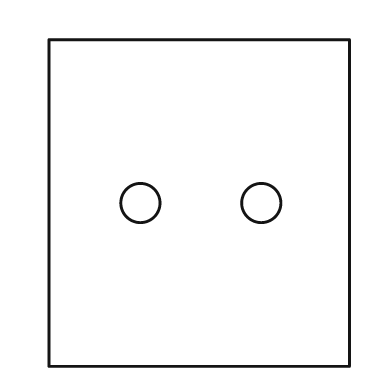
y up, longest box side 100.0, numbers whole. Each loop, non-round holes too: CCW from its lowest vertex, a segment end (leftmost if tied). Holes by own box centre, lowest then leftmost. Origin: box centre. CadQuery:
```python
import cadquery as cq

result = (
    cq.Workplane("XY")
    .moveTo(-46.0, -50.0)
    .lineTo(46.0, -50.0)
    .lineTo(46.0, 50.0)
    .lineTo(-46.0, 50.0)
    .close()
    .moveTo(-18.0, 0.0)
    .circle(6.0)
    .moveTo(19.0, 0.0)
    .circle(6.0)
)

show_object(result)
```